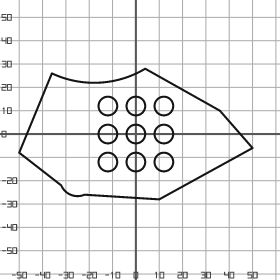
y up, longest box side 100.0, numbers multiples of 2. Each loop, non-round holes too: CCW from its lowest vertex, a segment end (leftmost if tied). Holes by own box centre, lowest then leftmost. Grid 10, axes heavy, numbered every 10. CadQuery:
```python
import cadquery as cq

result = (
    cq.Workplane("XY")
    .moveTo(10.0, -28.0)
    .lineTo(50.0, -6.0)
    .lineTo(36.0, 10.0)
    .lineTo(4.0, 28.0)
    .threePointArc((-16.0, 22.0), (-36.0, 26.0))
    .lineTo(-50.0, -8.0)
    .lineTo(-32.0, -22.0)
    .threePointArc((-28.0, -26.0), (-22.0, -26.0))
    .close()
    .moveTo(-12.0, -12.0)
    .circle(4.0)
    .moveTo(0.0, -12.0)
    .circle(4.0)
    .moveTo(12.0, -12.0)
    .circle(4.0)
    .moveTo(-12.0, 0.0)
    .circle(4.0)
    .moveTo(0.0, 0.0)
    .circle(4.0)
    .moveTo(12.0, 0.0)
    .circle(4.0)
    .moveTo(-12.0, 12.0)
    .circle(4.0)
    .moveTo(0.0, 12.0)
    .circle(4.0)
    .moveTo(12.0, 12.0)
    .circle(4.0)
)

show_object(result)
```